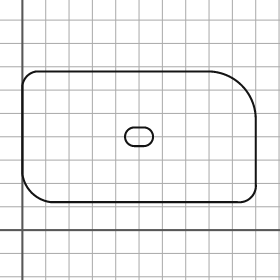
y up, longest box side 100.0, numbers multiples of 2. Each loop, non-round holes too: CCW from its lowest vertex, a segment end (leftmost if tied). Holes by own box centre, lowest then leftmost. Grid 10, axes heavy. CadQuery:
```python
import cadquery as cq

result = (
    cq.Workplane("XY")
    .moveTo(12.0, 12.0)
    .lineTo(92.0, 12.0)
    .threePointArc((98.0, 14.0), (100.0, 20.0))
    .lineTo(100.0, 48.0)
    .threePointArc((94.0, 62.0), (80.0, 68.0))
    .lineTo(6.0, 68.0)
    .threePointArc((2.0, 66.0), (0.0, 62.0))
    .lineTo(0.0, 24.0)
    .threePointArc((4.0, 16.0), (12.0, 12.0))
    .close()
    .moveTo(48.0, 36.0)
    .lineTo(52.0, 36.0)
    .threePointArc((56.0, 40.0), (52.0, 44.0))
    .lineTo(48.0, 44.0)
    .threePointArc((44.0, 40.0), (48.0, 36.0))
    .close()
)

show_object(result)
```